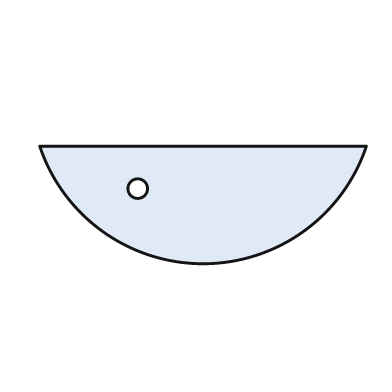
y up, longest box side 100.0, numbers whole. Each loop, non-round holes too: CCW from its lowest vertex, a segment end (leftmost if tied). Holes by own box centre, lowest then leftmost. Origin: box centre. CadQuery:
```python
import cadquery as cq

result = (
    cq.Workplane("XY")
    .moveTo(-50.0, 18.0)
    .threePointArc((0.0, -18.0), (50.0, 18.0))
    .close()
    .moveTo(-20.0, 5.0)
    .circle(3.0)
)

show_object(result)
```